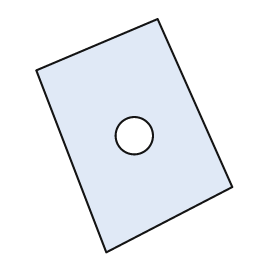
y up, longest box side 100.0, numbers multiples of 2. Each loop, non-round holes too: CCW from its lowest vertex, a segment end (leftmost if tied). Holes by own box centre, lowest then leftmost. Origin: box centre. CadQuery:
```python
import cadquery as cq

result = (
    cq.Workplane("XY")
    .moveTo(-12.0, -50.0)
    .lineTo(42.0, -22.0)
    .lineTo(10.0, 50.0)
    .lineTo(-42.0, 28.0)
    .close()
    .moveTo(0.0, 0.0)
    .circle(8.0)
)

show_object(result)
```